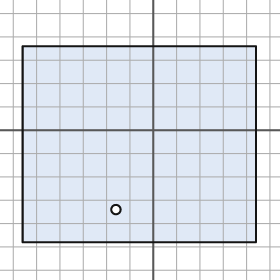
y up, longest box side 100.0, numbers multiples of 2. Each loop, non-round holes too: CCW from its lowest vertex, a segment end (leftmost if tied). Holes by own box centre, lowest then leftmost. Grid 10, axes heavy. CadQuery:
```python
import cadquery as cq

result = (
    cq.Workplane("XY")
    .moveTo(-56.0, -48.0)
    .lineTo(44.0, -48.0)
    .lineTo(44.0, 36.0)
    .lineTo(-56.0, 36.0)
    .close()
    .moveTo(-16.0, -34.0)
    .circle(2.0)
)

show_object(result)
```